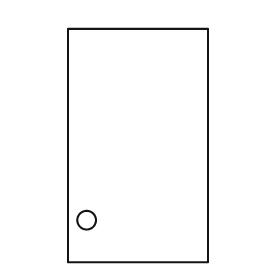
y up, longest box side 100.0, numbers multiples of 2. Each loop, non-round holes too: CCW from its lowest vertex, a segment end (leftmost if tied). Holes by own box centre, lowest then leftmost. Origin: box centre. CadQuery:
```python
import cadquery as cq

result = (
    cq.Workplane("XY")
    .moveTo(-30.0, -50.0)
    .lineTo(30.0, -50.0)
    .lineTo(30.0, 50.0)
    .lineTo(-30.0, 50.0)
    .close()
    .moveTo(-22.0, -32.0)
    .circle(4.0)
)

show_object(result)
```